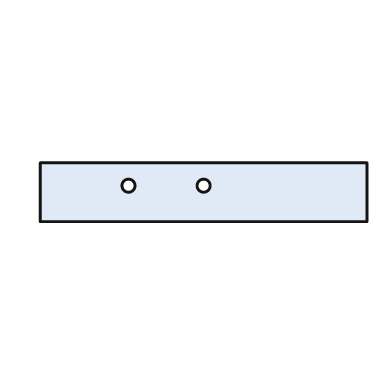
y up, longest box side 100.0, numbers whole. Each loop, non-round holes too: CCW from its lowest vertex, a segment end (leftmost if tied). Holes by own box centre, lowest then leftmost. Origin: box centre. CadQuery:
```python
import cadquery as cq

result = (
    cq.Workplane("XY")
    .moveTo(-50.0, -9.0)
    .lineTo(50.0, -9.0)
    .lineTo(50.0, 9.0)
    .lineTo(-50.0, 9.0)
    .close()
    .moveTo(-23.0, 2.0)
    .circle(2.0)
    .moveTo(0.0, 2.0)
    .circle(2.0)
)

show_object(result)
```